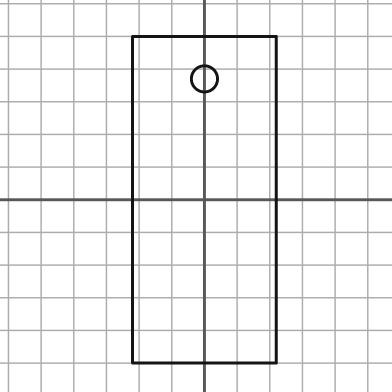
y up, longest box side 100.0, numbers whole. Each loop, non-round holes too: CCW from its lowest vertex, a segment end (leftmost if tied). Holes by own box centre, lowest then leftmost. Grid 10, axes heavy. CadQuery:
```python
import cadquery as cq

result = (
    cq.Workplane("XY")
    .moveTo(-22.0, -50.0)
    .lineTo(22.0, -50.0)
    .lineTo(22.0, 50.0)
    .lineTo(-22.0, 50.0)
    .close()
    .moveTo(0.0, 37.0)
    .circle(4.0)
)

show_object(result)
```